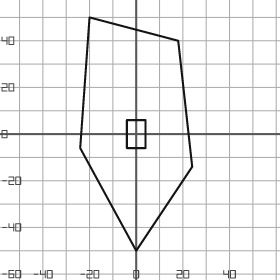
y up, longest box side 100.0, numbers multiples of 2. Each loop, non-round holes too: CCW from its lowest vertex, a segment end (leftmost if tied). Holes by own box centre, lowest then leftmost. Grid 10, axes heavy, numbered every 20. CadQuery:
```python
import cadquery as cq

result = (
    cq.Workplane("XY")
    .moveTo(0.0, -50.0)
    .lineTo(24.0, -14.0)
    .lineTo(18.0, 40.0)
    .lineTo(-20.0, 50.0)
    .lineTo(-24.0, -6.0)
    .close()
    .moveTo(-4.0, -6.0)
    .lineTo(4.0, -6.0)
    .lineTo(4.0, 6.0)
    .lineTo(-4.0, 6.0)
    .close()
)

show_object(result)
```